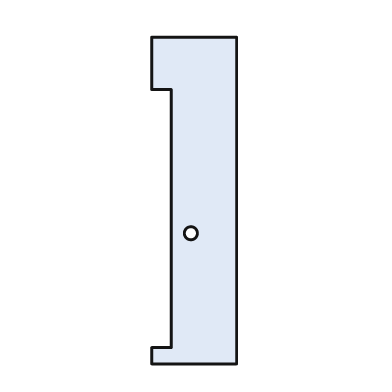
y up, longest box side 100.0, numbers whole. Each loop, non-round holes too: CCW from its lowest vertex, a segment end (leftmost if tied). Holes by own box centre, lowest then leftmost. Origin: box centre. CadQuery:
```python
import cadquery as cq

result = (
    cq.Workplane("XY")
    .moveTo(-13.0, -50.0)
    .lineTo(13.0, -50.0)
    .lineTo(13.0, 50.0)
    .lineTo(-13.0, 50.0)
    .lineTo(-13.0, 34.0)
    .lineTo(-7.0, 34.0)
    .lineTo(-7.0, -45.0)
    .lineTo(-13.0, -45.0)
    .close()
    .moveTo(-1.0, -10.0)
    .circle(2.0)
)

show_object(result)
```